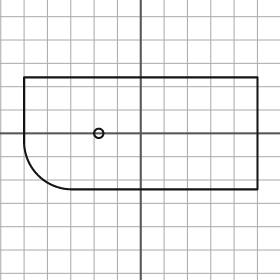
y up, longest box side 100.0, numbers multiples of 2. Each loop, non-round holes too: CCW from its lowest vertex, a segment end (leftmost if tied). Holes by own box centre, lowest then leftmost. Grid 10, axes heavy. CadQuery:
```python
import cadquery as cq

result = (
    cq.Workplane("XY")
    .moveTo(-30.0, -24.0)
    .lineTo(50.0, -24.0)
    .lineTo(50.0, 24.0)
    .lineTo(-50.0, 24.0)
    .lineTo(-50.0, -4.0)
    .threePointArc((-44.0, -18.0), (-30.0, -24.0))
    .close()
    .moveTo(-18.0, 0.0)
    .circle(2.0)
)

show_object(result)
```